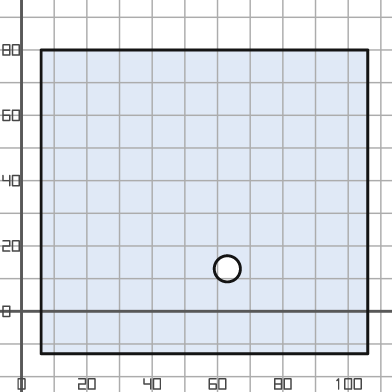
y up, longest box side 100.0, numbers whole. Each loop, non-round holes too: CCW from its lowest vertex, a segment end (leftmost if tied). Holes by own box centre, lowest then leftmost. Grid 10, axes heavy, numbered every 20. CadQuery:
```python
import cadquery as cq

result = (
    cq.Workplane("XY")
    .moveTo(6.0, -13.0)
    .lineTo(106.0, -13.0)
    .lineTo(106.0, 80.0)
    .lineTo(6.0, 80.0)
    .close()
    .moveTo(63.0, 13.0)
    .circle(4.0)
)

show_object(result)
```